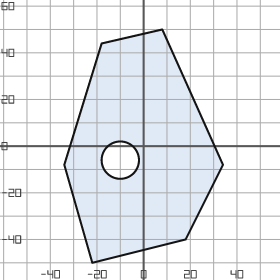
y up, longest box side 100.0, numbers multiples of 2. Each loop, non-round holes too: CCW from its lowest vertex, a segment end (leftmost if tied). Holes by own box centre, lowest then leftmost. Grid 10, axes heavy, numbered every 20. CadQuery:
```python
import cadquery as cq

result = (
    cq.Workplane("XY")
    .moveTo(-22.0, -50.0)
    .lineTo(18.0, -40.0)
    .lineTo(34.0, -8.0)
    .lineTo(8.0, 50.0)
    .lineTo(-18.0, 44.0)
    .lineTo(-34.0, -8.0)
    .close()
    .moveTo(-10.0, -6.0)
    .circle(8.0)
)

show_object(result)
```